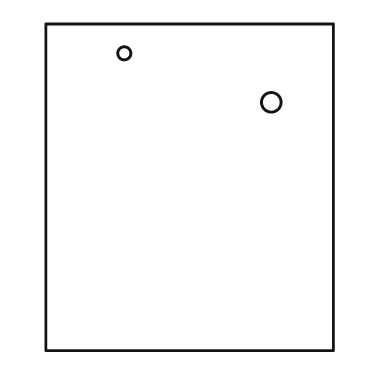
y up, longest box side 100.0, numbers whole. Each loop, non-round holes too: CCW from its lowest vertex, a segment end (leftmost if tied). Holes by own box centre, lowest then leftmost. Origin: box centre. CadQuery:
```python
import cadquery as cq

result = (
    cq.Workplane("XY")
    .moveTo(-44.0, -50.0)
    .lineTo(44.0, -50.0)
    .lineTo(44.0, 50.0)
    .lineTo(-44.0, 50.0)
    .close()
    .moveTo(25.0, 26.0)
    .circle(3.0)
    .moveTo(-20.0, 41.0)
    .circle(2.0)
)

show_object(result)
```